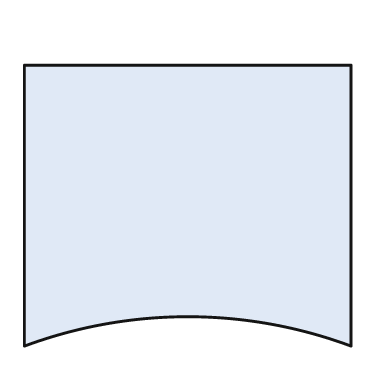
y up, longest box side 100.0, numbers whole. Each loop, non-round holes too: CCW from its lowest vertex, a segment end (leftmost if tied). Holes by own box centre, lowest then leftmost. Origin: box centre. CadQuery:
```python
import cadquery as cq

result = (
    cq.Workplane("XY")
    .moveTo(-50.0, -43.0)
    .threePointArc((0.0, -34.0), (50.0, -43.0))
    .lineTo(50.0, 43.0)
    .lineTo(-50.0, 43.0)
    .close()
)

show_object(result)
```